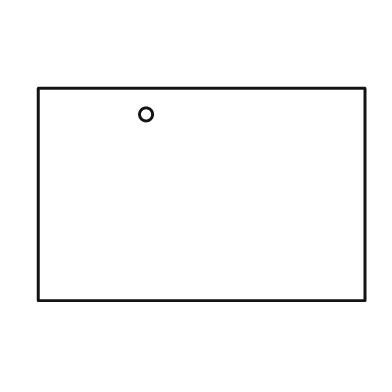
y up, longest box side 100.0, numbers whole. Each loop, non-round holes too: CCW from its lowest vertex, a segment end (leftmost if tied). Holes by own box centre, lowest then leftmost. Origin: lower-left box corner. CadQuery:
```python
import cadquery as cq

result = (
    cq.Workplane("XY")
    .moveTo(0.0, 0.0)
    .lineTo(100.0, 0.0)
    .lineTo(100.0, 65.0)
    .lineTo(0.0, 65.0)
    .close()
    .moveTo(33.0, 57.0)
    .circle(2.0)
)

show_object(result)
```